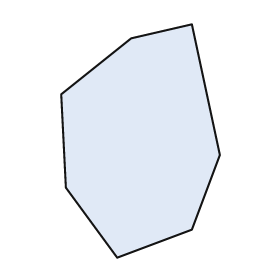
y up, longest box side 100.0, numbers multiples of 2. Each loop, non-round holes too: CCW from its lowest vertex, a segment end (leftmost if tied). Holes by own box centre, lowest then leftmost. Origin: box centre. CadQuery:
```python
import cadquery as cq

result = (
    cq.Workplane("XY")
    .moveTo(-10.0, -50.0)
    .lineTo(22.0, -38.0)
    .lineTo(34.0, -6.0)
    .lineTo(22.0, 50.0)
    .lineTo(-4.0, 44.0)
    .lineTo(-34.0, 20.0)
    .lineTo(-32.0, -20.0)
    .close()
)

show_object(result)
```